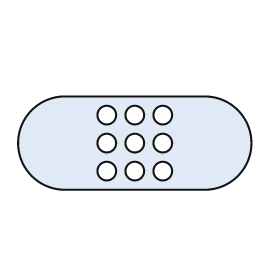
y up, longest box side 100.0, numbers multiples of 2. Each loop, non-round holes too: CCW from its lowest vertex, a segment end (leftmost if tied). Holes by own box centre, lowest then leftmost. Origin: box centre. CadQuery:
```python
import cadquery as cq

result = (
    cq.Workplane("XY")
    .moveTo(-30.0, -20.0)
    .lineTo(30.0, -20.0)
    .threePointArc((50.0, 0.0), (30.0, 20.0))
    .lineTo(-30.0, 20.0)
    .threePointArc((-50.0, 0.0), (-30.0, -20.0))
    .close()
    .moveTo(-12.0, -12.0)
    .circle(4.0)
    .moveTo(0.0, -12.0)
    .circle(4.0)
    .moveTo(12.0, -12.0)
    .circle(4.0)
    .moveTo(-12.0, 0.0)
    .circle(4.0)
    .moveTo(0.0, 0.0)
    .circle(4.0)
    .moveTo(12.0, 0.0)
    .circle(4.0)
    .moveTo(-12.0, 12.0)
    .circle(4.0)
    .moveTo(0.0, 12.0)
    .circle(4.0)
    .moveTo(12.0, 12.0)
    .circle(4.0)
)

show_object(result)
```